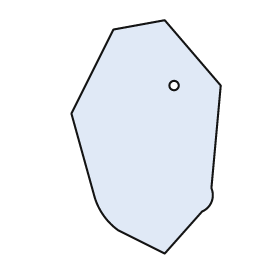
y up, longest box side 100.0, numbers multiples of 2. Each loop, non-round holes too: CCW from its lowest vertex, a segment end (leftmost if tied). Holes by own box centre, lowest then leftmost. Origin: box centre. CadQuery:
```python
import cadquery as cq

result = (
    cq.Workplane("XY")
    .moveTo(8.0, -50.0)
    .lineTo(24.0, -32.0)
    .threePointArc((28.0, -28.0), (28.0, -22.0))
    .lineTo(32.0, 22.0)
    .lineTo(8.0, 50.0)
    .lineTo(-14.0, 46.0)
    .lineTo(-32.0, 10.0)
    .lineTo(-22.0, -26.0)
    .threePointArc((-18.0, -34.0), (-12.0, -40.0))
    .close()
    .moveTo(12.0, 22.0)
    .circle(2.0)
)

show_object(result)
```